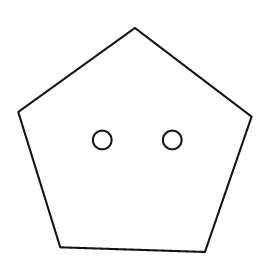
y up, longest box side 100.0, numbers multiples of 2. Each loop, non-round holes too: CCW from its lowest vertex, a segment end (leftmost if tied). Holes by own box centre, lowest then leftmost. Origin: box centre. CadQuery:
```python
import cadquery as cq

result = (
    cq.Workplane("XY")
    .moveTo(30.0, -48.0)
    .lineTo(50.0, 10.0)
    .lineTo(0.0, 48.0)
    .lineTo(-50.0, 12.0)
    .lineTo(-32.0, -46.0)
    .close()
    .moveTo(-14.0, 0.0)
    .circle(4.0)
    .moveTo(16.0, 0.0)
    .circle(4.0)
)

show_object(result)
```